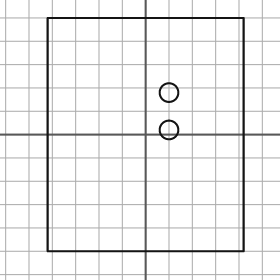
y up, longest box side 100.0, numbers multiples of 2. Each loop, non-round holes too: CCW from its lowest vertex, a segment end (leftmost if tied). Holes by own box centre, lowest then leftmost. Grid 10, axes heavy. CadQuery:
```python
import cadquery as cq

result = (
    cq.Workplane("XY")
    .moveTo(-42.0, -50.0)
    .lineTo(42.0, -50.0)
    .lineTo(42.0, 50.0)
    .lineTo(-42.0, 50.0)
    .close()
    .moveTo(10.0, 2.0)
    .circle(4.0)
    .moveTo(10.0, 18.0)
    .circle(4.0)
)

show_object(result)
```